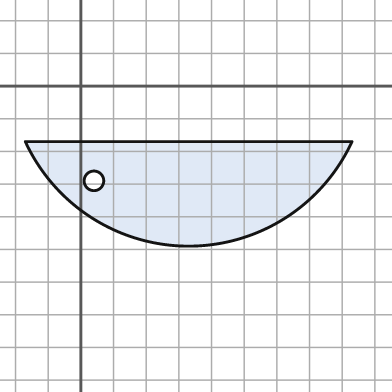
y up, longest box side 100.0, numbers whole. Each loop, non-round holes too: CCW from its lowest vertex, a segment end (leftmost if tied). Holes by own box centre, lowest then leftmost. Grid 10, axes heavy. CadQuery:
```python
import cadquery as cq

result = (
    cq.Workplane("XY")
    .moveTo(-17.0, -17.0)
    .threePointArc((33.0, -49.0), (83.0, -17.0))
    .close()
    .moveTo(4.0, -29.0)
    .circle(3.0)
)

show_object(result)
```